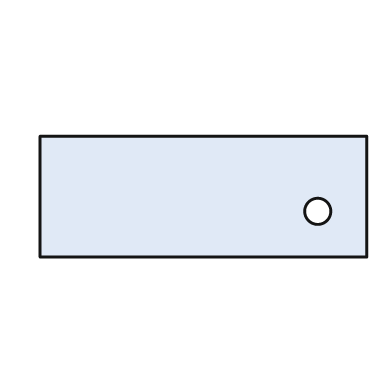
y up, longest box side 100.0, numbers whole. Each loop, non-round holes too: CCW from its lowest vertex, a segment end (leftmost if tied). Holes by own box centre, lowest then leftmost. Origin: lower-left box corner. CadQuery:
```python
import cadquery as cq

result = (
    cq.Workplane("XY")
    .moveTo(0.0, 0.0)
    .lineTo(100.0, 0.0)
    .lineTo(100.0, 37.0)
    .lineTo(0.0, 37.0)
    .close()
    .moveTo(85.0, 14.0)
    .circle(4.0)
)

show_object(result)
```